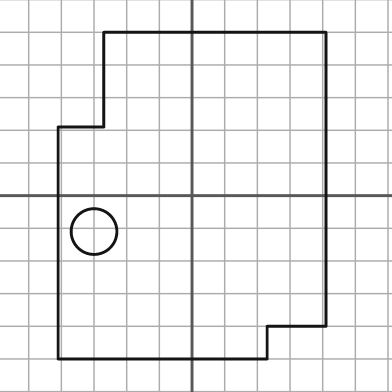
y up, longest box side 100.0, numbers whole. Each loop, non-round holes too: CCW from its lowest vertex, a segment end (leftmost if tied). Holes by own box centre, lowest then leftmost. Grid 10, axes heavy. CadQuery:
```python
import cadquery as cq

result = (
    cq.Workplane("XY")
    .moveTo(-41.0, -50.0)
    .lineTo(23.0, -50.0)
    .lineTo(23.0, -40.0)
    .lineTo(41.0, -40.0)
    .lineTo(41.0, 50.0)
    .lineTo(-27.0, 50.0)
    .lineTo(-27.0, 21.0)
    .lineTo(-41.0, 21.0)
    .close()
    .moveTo(-30.0, -11.0)
    .circle(7.0)
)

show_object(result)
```